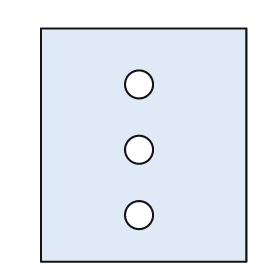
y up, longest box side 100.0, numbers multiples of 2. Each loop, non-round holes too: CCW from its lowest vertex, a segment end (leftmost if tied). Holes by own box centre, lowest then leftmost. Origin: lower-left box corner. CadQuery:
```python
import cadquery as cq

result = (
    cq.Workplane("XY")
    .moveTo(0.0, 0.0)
    .lineTo(88.0, 0.0)
    .lineTo(88.0, 100.0)
    .lineTo(0.0, 100.0)
    .close()
    .moveTo(42.0, 20.0)
    .circle(6.0)
    .moveTo(42.0, 48.0)
    .circle(6.0)
    .moveTo(42.0, 76.0)
    .circle(6.0)
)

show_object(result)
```